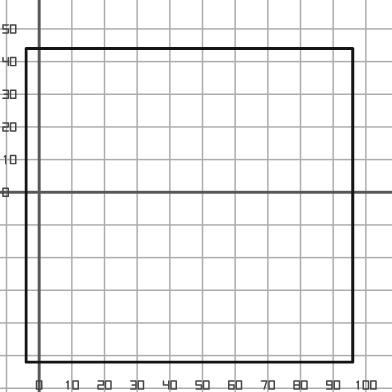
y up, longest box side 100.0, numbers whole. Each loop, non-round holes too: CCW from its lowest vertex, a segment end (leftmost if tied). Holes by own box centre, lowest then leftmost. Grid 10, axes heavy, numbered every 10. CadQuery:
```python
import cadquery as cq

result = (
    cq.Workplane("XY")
    .moveTo(-4.0, -52.0)
    .lineTo(96.0, -52.0)
    .lineTo(96.0, 44.0)
    .lineTo(-4.0, 44.0)
    .close()
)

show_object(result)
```